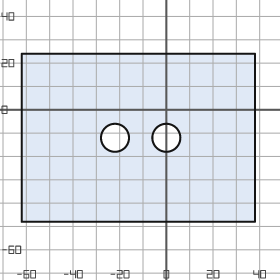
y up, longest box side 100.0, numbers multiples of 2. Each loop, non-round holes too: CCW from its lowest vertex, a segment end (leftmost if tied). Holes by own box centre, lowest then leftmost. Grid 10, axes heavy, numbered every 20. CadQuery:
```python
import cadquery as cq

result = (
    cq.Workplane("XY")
    .moveTo(-62.0, -48.0)
    .lineTo(38.0, -48.0)
    .lineTo(38.0, 24.0)
    .lineTo(-62.0, 24.0)
    .close()
    .moveTo(-22.0, -12.0)
    .circle(6.0)
    .moveTo(0.0, -12.0)
    .circle(6.0)
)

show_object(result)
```